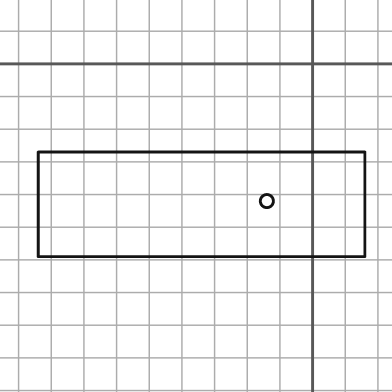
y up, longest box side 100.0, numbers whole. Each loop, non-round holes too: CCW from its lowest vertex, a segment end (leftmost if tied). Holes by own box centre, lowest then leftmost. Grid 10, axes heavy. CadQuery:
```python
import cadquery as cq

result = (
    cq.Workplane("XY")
    .moveTo(-84.0, -59.0)
    .lineTo(16.0, -59.0)
    .lineTo(16.0, -27.0)
    .lineTo(-84.0, -27.0)
    .close()
    .moveTo(-14.0, -42.0)
    .circle(2.0)
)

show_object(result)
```